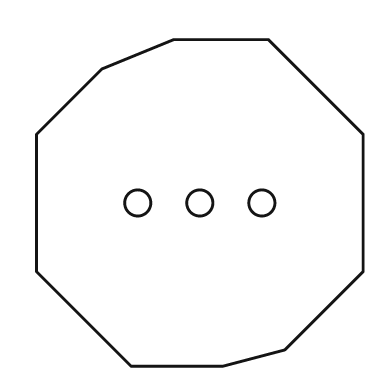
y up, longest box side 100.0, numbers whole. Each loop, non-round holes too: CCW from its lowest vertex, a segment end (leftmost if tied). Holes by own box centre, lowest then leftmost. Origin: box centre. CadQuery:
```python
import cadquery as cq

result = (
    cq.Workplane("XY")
    .moveTo(-21.0, -50.0)
    .lineTo(7.0, -50.0)
    .lineTo(26.0, -45.0)
    .lineTo(50.0, -21.0)
    .lineTo(50.0, 21.0)
    .lineTo(21.0, 50.0)
    .lineTo(-8.0, 50.0)
    .lineTo(-30.0, 41.0)
    .lineTo(-50.0, 21.0)
    .lineTo(-50.0, -21.0)
    .close()
    .moveTo(-19.0, 0.0)
    .circle(4.0)
    .moveTo(0.0, 0.0)
    .circle(4.0)
    .moveTo(19.0, 0.0)
    .circle(4.0)
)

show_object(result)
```